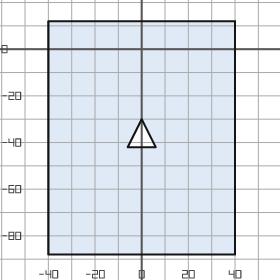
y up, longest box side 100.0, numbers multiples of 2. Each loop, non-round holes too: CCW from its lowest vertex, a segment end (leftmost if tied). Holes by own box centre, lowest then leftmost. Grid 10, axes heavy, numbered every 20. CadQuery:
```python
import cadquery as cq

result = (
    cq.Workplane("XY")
    .moveTo(-40.0, -88.0)
    .lineTo(40.0, -88.0)
    .lineTo(40.0, 12.0)
    .lineTo(-40.0, 12.0)
    .close()
    .moveTo(-6.0, -42.0)
    .lineTo(6.0, -42.0)
    .lineTo(0.0, -30.0)
    .close()
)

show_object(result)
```